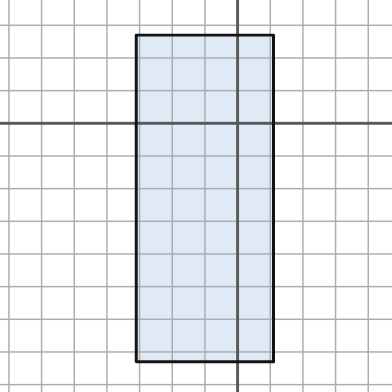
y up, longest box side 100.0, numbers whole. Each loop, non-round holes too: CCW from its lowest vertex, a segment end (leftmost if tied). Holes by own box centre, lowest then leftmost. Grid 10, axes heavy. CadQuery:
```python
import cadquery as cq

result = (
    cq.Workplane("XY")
    .moveTo(-31.0, -73.0)
    .lineTo(11.0, -73.0)
    .lineTo(11.0, 27.0)
    .lineTo(-31.0, 27.0)
    .close()
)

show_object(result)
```